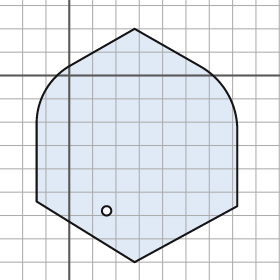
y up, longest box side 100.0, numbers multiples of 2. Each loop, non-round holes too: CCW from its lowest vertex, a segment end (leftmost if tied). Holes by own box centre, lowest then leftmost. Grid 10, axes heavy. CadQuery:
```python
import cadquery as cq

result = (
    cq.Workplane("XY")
    .moveTo(28.0, -80.0)
    .lineTo(72.0, -56.0)
    .lineTo(72.0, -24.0)
    .threePointArc((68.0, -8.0), (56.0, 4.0))
    .lineTo(28.0, 20.0)
    .lineTo(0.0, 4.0)
    .threePointArc((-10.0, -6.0), (-14.0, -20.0))
    .lineTo(-14.0, -54.0)
    .close()
    .moveTo(16.0, -58.0)
    .circle(2.0)
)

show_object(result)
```